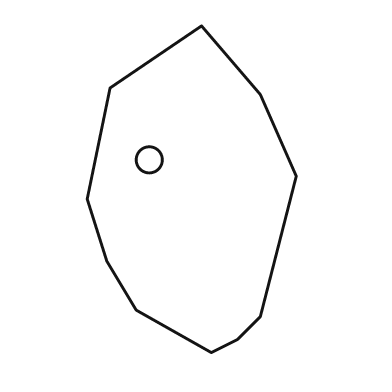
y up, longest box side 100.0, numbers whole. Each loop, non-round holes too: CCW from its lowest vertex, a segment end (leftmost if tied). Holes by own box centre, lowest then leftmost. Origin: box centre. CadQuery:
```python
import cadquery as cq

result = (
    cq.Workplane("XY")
    .moveTo(6.0, -50.0)
    .lineTo(14.0, -46.0)
    .lineTo(21.0, -39.0)
    .lineTo(32.0, 4.0)
    .lineTo(21.0, 29.0)
    .lineTo(3.0, 50.0)
    .lineTo(-25.0, 31.0)
    .lineTo(-32.0, -3.0)
    .lineTo(-26.0, -22.0)
    .lineTo(-17.0, -37.0)
    .close()
    .moveTo(-13.0, 9.0)
    .circle(4.0)
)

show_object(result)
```